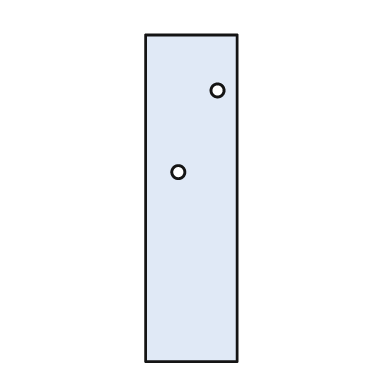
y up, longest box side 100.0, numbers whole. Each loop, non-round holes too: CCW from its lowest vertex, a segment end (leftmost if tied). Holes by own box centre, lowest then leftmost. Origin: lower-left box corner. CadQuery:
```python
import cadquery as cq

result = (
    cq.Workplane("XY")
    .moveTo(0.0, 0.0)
    .lineTo(28.0, 0.0)
    .lineTo(28.0, 100.0)
    .lineTo(0.0, 100.0)
    .close()
    .moveTo(10.0, 58.0)
    .circle(2.0)
    .moveTo(22.0, 83.0)
    .circle(2.0)
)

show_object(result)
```